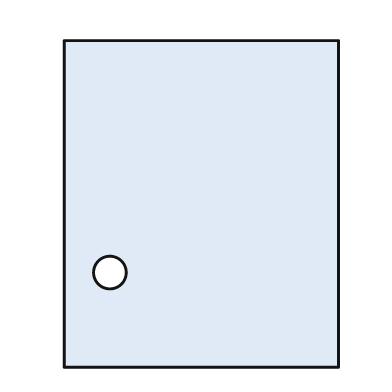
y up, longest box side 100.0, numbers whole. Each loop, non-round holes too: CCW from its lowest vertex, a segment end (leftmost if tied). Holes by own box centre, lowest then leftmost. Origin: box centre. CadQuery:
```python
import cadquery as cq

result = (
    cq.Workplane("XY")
    .moveTo(-42.0, -50.0)
    .lineTo(42.0, -50.0)
    .lineTo(42.0, 50.0)
    .lineTo(-42.0, 50.0)
    .close()
    .moveTo(-28.0, -21.0)
    .circle(5.0)
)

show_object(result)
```